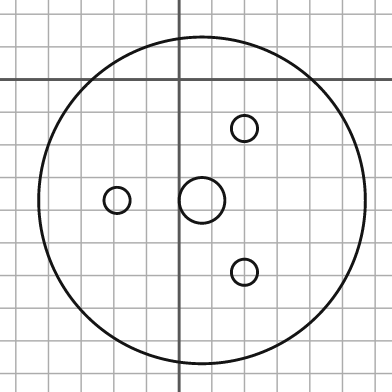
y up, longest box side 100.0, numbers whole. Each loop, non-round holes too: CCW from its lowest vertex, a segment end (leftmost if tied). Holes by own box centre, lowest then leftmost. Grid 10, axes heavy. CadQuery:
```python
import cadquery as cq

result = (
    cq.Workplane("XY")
    .moveTo(7.0, -37.0)
    .circle(50.0)
    .moveTo(20.0, -59.0)
    .circle(4.0)
    .moveTo(-19.0, -37.0)
    .circle(4.0)
    .moveTo(7.0, -37.0)
    .circle(7.0)
    .moveTo(20.0, -15.0)
    .circle(4.0)
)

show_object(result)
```